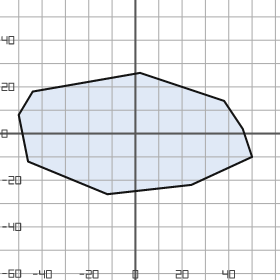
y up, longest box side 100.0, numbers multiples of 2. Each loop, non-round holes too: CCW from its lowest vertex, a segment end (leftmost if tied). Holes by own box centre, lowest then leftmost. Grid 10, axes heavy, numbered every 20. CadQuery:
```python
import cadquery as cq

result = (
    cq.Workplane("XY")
    .moveTo(-12.0, -26.0)
    .lineTo(24.0, -22.0)
    .lineTo(50.0, -10.0)
    .lineTo(46.0, 2.0)
    .lineTo(38.0, 14.0)
    .lineTo(2.0, 26.0)
    .lineTo(-44.0, 18.0)
    .lineTo(-50.0, 8.0)
    .lineTo(-46.0, -12.0)
    .close()
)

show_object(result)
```